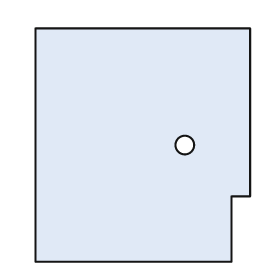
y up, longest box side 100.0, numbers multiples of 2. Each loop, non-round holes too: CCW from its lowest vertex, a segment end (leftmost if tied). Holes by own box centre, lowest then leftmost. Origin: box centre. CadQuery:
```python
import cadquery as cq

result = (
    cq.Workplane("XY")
    .moveTo(-46.0, -50.0)
    .lineTo(38.0, -50.0)
    .lineTo(38.0, -22.0)
    .lineTo(46.0, -22.0)
    .lineTo(46.0, 50.0)
    .lineTo(-46.0, 50.0)
    .close()
    .moveTo(18.0, 0.0)
    .circle(4.0)
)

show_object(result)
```